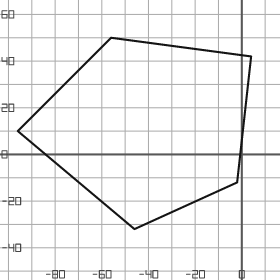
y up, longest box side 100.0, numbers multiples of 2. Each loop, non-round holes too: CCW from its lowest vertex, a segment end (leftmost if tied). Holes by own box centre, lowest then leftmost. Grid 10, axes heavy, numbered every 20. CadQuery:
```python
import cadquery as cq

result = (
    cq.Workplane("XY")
    .moveTo(-46.0, -32.0)
    .lineTo(-2.0, -12.0)
    .lineTo(4.0, 42.0)
    .lineTo(-56.0, 50.0)
    .lineTo(-96.0, 10.0)
    .close()
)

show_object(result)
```